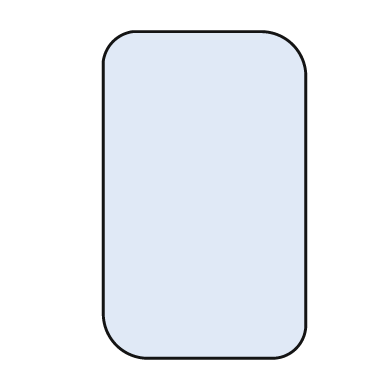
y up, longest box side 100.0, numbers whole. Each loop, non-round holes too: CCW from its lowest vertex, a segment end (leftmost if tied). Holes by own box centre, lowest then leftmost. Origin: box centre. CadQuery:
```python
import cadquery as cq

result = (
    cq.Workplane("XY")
    .moveTo(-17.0, -50.0)
    .lineTo(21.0, -50.0)
    .threePointArc((28.0, -47.0), (31.0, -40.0))
    .lineTo(31.0, 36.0)
    .threePointArc((27.0, 46.0), (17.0, 50.0))
    .lineTo(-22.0, 50.0)
    .threePointArc((-28.0, 47.0), (-31.0, 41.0))
    .lineTo(-31.0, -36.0)
    .threePointArc((-27.0, -46.0), (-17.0, -50.0))
    .close()
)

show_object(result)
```